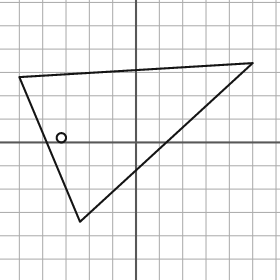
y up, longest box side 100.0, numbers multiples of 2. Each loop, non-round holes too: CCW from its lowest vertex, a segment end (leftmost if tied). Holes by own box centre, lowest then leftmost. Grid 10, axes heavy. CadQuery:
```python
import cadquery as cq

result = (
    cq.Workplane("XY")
    .moveTo(-24.0, -34.0)
    .lineTo(50.0, 34.0)
    .lineTo(-50.0, 28.0)
    .close()
    .moveTo(-32.0, 2.0)
    .circle(2.0)
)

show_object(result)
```